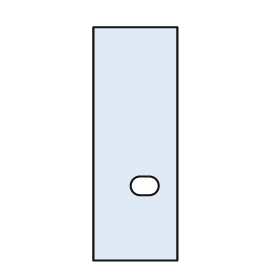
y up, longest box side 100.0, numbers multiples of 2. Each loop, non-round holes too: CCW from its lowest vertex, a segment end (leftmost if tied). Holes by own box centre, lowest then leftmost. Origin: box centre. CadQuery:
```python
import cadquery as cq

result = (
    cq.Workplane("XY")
    .moveTo(-18.0, -50.0)
    .lineTo(18.0, -50.0)
    .lineTo(18.0, 50.0)
    .lineTo(-18.0, 50.0)
    .close()
    .moveTo(2.0, -22.0)
    .lineTo(6.0, -22.0)
    .threePointArc((10.0, -18.0), (6.0, -14.0))
    .lineTo(2.0, -14.0)
    .threePointArc((-2.0, -18.0), (2.0, -22.0))
    .close()
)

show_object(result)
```